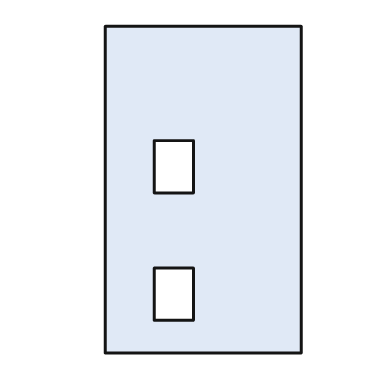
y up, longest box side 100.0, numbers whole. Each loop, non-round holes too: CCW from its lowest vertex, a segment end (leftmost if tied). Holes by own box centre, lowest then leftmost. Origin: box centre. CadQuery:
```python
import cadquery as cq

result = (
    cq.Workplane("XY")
    .moveTo(-30.0, -50.0)
    .lineTo(30.0, -50.0)
    .lineTo(30.0, 50.0)
    .lineTo(-30.0, 50.0)
    .close()
    .moveTo(-15.0, -40.0)
    .lineTo(-3.0, -40.0)
    .lineTo(-3.0, -24.0)
    .lineTo(-15.0, -24.0)
    .close()
    .moveTo(-15.0, -1.0)
    .lineTo(-3.0, -1.0)
    .lineTo(-3.0, 15.0)
    .lineTo(-15.0, 15.0)
    .close()
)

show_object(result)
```